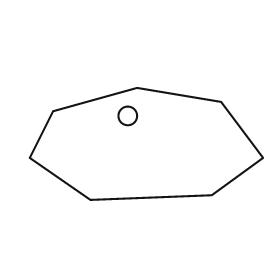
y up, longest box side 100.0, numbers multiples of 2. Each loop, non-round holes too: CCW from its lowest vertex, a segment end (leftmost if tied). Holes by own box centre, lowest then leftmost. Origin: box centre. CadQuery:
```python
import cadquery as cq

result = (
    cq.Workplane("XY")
    .moveTo(-24.0, -24.0)
    .lineTo(28.0, -22.0)
    .lineTo(50.0, -6.0)
    .lineTo(32.0, 18.0)
    .lineTo(-4.0, 24.0)
    .lineTo(-40.0, 14.0)
    .lineTo(-50.0, -6.0)
    .close()
    .moveTo(-8.0, 12.0)
    .circle(4.0)
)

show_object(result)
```